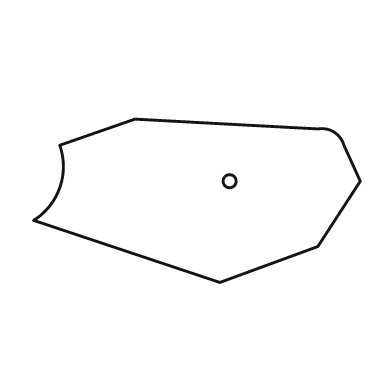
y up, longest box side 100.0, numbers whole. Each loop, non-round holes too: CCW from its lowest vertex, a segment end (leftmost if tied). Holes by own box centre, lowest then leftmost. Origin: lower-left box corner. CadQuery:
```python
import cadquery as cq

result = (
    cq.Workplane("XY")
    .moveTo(57.0, 0.0)
    .lineTo(87.0, 11.0)
    .lineTo(100.0, 31.0)
    .lineTo(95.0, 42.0)
    .threePointArc((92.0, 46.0), (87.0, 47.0))
    .lineTo(31.0, 50.0)
    .lineTo(8.0, 42.0)
    .threePointArc((8.0, 29.0), (0.0, 19.0))
    .close()
    .moveTo(60.0, 31.0)
    .circle(2.0)
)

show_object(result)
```